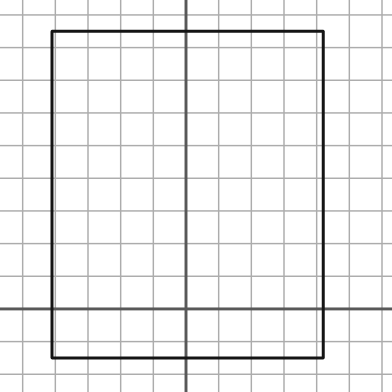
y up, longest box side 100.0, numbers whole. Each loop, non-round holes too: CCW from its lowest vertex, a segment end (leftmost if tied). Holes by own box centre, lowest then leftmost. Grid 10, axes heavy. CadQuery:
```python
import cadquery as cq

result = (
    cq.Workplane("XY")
    .moveTo(-41.0, -15.0)
    .lineTo(42.0, -15.0)
    .lineTo(42.0, 85.0)
    .lineTo(-41.0, 85.0)
    .close()
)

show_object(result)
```